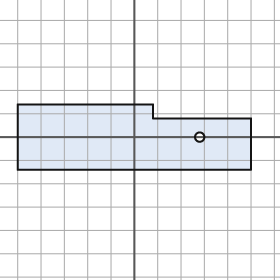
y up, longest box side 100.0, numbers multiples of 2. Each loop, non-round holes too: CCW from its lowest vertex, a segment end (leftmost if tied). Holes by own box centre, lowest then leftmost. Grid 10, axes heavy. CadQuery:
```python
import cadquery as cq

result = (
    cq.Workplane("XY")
    .moveTo(-50.0, -14.0)
    .lineTo(50.0, -14.0)
    .lineTo(50.0, 8.0)
    .lineTo(8.0, 8.0)
    .lineTo(8.0, 14.0)
    .lineTo(-50.0, 14.0)
    .close()
    .moveTo(28.0, 0.0)
    .circle(2.0)
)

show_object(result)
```